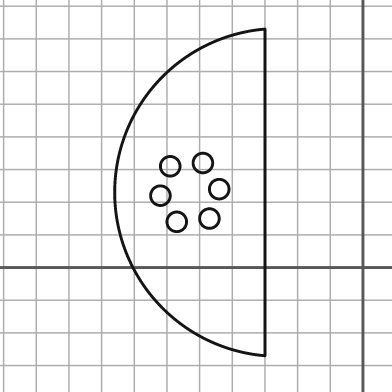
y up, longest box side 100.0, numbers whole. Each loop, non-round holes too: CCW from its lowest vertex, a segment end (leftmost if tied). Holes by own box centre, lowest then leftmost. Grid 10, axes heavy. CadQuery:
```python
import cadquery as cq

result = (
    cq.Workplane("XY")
    .moveTo(-30.0, -27.0)
    .lineTo(-30.0, 73.0)
    .threePointArc((-76.0, 23.0), (-30.0, -27.0))
    .close()
    .moveTo(-57.0, 14.0)
    .circle(3.0)
    .moveTo(-47.0, 15.0)
    .circle(3.0)
    .moveTo(-62.0, 22.0)
    .circle(3.0)
    .moveTo(-44.0, 24.0)
    .circle(3.0)
    .moveTo(-59.0, 31.0)
    .circle(3.0)
    .moveTo(-49.0, 32.0)
    .circle(3.0)
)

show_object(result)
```